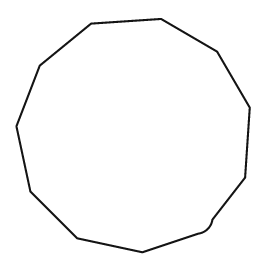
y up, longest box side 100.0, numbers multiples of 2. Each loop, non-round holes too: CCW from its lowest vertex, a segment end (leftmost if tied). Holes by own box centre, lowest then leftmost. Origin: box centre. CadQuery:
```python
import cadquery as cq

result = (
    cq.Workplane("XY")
    .moveTo(4.0, -50.0)
    .lineTo(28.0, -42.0)
    .threePointArc((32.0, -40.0), (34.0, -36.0))
    .lineTo(48.0, -18.0)
    .lineTo(50.0, 12.0)
    .lineTo(36.0, 36.0)
    .lineTo(12.0, 50.0)
    .lineTo(-18.0, 48.0)
    .lineTo(-40.0, 30.0)
    .lineTo(-50.0, 4.0)
    .lineTo(-44.0, -24.0)
    .lineTo(-24.0, -44.0)
    .close()
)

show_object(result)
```